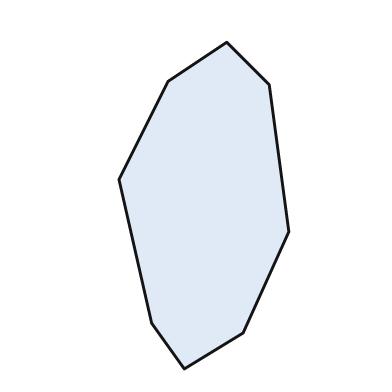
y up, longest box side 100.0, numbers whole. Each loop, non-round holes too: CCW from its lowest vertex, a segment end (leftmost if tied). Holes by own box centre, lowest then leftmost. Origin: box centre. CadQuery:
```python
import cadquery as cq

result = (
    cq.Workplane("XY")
    .moveTo(-6.0, -50.0)
    .lineTo(12.0, -39.0)
    .lineTo(26.0, -8.0)
    .lineTo(20.0, 37.0)
    .lineTo(7.0, 50.0)
    .lineTo(-11.0, 38.0)
    .lineTo(-26.0, 8.0)
    .lineTo(-16.0, -36.0)
    .close()
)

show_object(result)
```